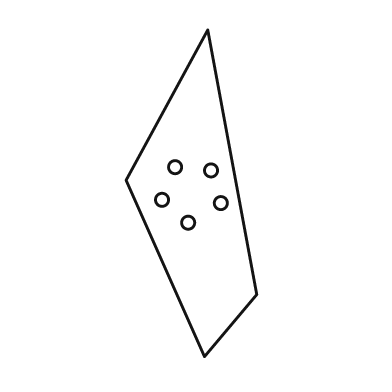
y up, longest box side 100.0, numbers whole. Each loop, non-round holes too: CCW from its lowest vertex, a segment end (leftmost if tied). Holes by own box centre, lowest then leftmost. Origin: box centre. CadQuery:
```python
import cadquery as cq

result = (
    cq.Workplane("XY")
    .moveTo(4.0, -50.0)
    .lineTo(20.0, -31.0)
    .lineTo(5.0, 50.0)
    .lineTo(-20.0, 4.0)
    .close()
    .moveTo(-1.0, -9.0)
    .circle(2.0)
    .moveTo(9.0, -3.0)
    .circle(2.0)
    .moveTo(-9.0, -2.0)
    .circle(2.0)
    .moveTo(6.0, 7.0)
    .circle(2.0)
    .moveTo(-5.0, 8.0)
    .circle(2.0)
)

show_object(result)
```